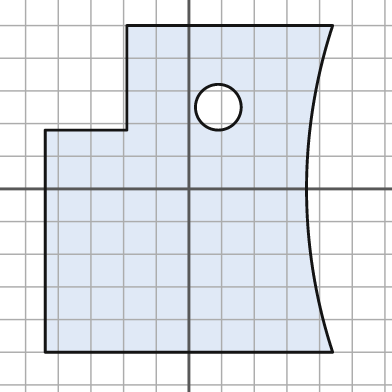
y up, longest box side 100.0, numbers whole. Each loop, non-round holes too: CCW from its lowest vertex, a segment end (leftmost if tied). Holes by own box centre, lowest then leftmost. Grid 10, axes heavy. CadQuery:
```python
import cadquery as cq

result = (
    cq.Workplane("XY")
    .moveTo(-44.0, -50.0)
    .lineTo(44.0, -50.0)
    .threePointArc((36.0, 0.0), (44.0, 50.0))
    .lineTo(-19.0, 50.0)
    .lineTo(-19.0, 18.0)
    .lineTo(-44.0, 18.0)
    .close()
    .moveTo(9.0, 25.0)
    .circle(7.0)
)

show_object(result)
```